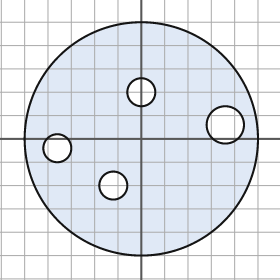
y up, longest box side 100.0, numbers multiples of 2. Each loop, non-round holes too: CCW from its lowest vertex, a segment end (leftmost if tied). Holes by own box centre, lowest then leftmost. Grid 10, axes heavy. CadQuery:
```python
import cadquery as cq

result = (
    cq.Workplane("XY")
    .moveTo(0.0, 0.0)
    .circle(50.0)
    .moveTo(-12.0, -20.0)
    .circle(6.0)
    .moveTo(-36.0, -4.0)
    .circle(6.0)
    .moveTo(36.0, 6.0)
    .circle(8.0)
    .moveTo(0.0, 20.0)
    .circle(6.0)
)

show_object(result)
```